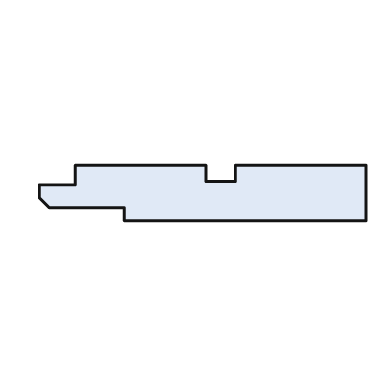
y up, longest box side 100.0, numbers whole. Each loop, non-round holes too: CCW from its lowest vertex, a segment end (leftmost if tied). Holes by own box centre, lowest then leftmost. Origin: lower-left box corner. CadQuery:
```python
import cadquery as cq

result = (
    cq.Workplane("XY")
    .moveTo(26.0, 0.0)
    .lineTo(100.0, 0.0)
    .lineTo(100.0, 17.0)
    .lineTo(60.0, 17.0)
    .lineTo(60.0, 12.0)
    .lineTo(51.0, 12.0)
    .lineTo(51.0, 17.0)
    .lineTo(11.0, 17.0)
    .lineTo(11.0, 11.0)
    .lineTo(0.0, 11.0)
    .lineTo(0.0, 7.0)
    .lineTo(3.0, 4.0)
    .lineTo(26.0, 4.0)
    .close()
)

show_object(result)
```